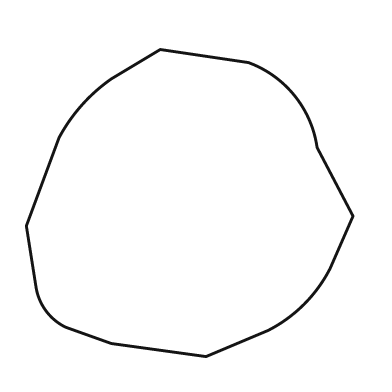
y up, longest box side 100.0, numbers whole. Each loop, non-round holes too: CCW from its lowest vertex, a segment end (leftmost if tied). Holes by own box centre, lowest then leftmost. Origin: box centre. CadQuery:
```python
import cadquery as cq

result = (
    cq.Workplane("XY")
    .moveTo(5.0, -47.0)
    .lineTo(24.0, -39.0)
    .threePointArc((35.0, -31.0), (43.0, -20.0))
    .lineTo(50.0, -4.0)
    .lineTo(39.0, 17.0)
    .threePointArc((32.0, 33.0), (18.0, 43.0))
    .lineTo(-9.0, 47.0)
    .lineTo(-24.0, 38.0)
    .threePointArc((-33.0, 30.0), (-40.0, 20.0))
    .lineTo(-50.0, -7.0)
    .lineTo(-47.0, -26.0)
    .threePointArc((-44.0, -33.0), (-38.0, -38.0))
    .lineTo(-24.0, -43.0)
    .close()
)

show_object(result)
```